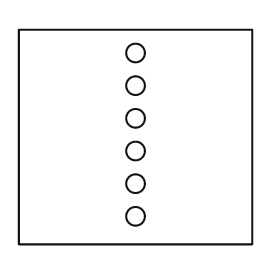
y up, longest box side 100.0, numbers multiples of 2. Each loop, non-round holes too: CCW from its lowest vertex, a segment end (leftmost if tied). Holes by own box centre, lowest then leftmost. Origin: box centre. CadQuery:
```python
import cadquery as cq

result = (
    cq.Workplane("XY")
    .moveTo(-50.0, -46.0)
    .lineTo(50.0, -46.0)
    .lineTo(50.0, 46.0)
    .lineTo(-50.0, 46.0)
    .close()
    .moveTo(0.0, -34.0)
    .circle(4.0)
    .moveTo(0.0, -20.0)
    .circle(4.0)
    .moveTo(0.0, -6.0)
    .circle(4.0)
    .moveTo(0.0, 8.0)
    .circle(4.0)
    .moveTo(0.0, 22.0)
    .circle(4.0)
    .moveTo(0.0, 36.0)
    .circle(4.0)
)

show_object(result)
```